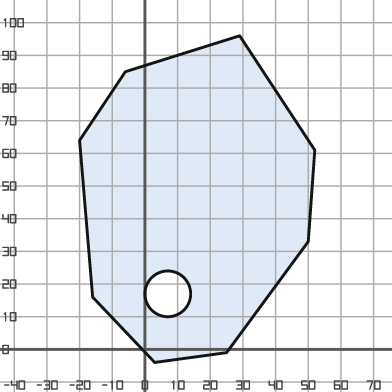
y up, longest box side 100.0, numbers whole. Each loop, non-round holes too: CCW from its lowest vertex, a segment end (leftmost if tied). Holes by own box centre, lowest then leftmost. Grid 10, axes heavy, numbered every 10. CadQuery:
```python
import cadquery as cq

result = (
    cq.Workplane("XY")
    .moveTo(3.0, -4.0)
    .lineTo(25.0, -1.0)
    .lineTo(50.0, 33.0)
    .lineTo(52.0, 61.0)
    .lineTo(29.0, 96.0)
    .lineTo(-6.0, 85.0)
    .lineTo(-20.0, 64.0)
    .lineTo(-16.0, 16.0)
    .close()
    .moveTo(7.0, 17.0)
    .circle(7.0)
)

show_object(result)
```